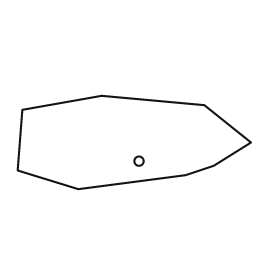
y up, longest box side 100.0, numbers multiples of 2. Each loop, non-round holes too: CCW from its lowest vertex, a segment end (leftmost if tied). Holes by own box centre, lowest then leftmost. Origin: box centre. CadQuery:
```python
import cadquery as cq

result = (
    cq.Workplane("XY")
    .moveTo(-24.0, -20.0)
    .lineTo(22.0, -14.0)
    .lineTo(34.0, -10.0)
    .lineTo(50.0, 0.0)
    .lineTo(30.0, 16.0)
    .lineTo(-14.0, 20.0)
    .lineTo(-48.0, 14.0)
    .lineTo(-50.0, -12.0)
    .close()
    .moveTo(2.0, -8.0)
    .circle(2.0)
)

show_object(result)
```